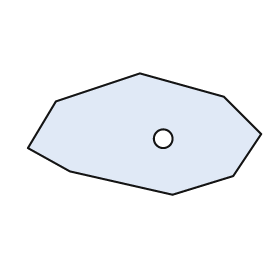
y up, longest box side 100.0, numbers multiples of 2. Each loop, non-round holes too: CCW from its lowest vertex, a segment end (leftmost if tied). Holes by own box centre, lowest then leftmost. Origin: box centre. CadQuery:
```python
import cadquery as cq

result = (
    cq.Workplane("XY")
    .moveTo(12.0, -26.0)
    .lineTo(38.0, -18.0)
    .lineTo(50.0, 0.0)
    .lineTo(34.0, 16.0)
    .lineTo(-2.0, 26.0)
    .lineTo(-38.0, 14.0)
    .lineTo(-50.0, -6.0)
    .lineTo(-32.0, -16.0)
    .close()
    .moveTo(8.0, -2.0)
    .circle(4.0)
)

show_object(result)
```